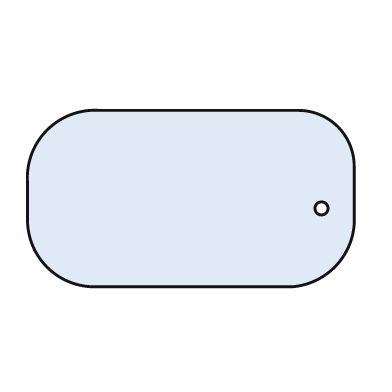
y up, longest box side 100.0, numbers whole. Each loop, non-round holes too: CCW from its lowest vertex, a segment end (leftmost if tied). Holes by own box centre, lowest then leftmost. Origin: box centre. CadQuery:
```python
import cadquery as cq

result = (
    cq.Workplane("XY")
    .moveTo(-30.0, -27.0)
    .lineTo(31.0, -27.0)
    .threePointArc((44.0, -21.0), (50.0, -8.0))
    .lineTo(50.0, 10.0)
    .threePointArc((45.0, 22.0), (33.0, 27.0))
    .lineTo(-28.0, 27.0)
    .threePointArc((-44.0, 21.0), (-50.0, 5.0))
    .lineTo(-50.0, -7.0)
    .threePointArc((-44.0, -21.0), (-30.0, -27.0))
    .close()
    .moveTo(40.0, -3.0)
    .circle(2.0)
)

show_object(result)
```